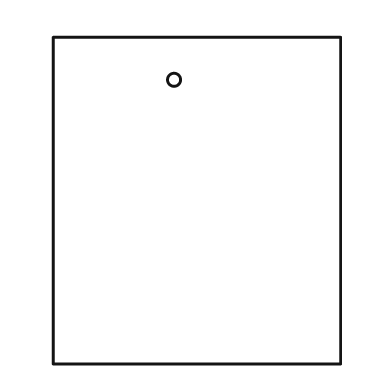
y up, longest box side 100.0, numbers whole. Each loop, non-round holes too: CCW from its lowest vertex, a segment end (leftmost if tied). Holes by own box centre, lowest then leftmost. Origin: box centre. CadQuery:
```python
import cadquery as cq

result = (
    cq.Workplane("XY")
    .moveTo(-44.0, -50.0)
    .lineTo(44.0, -50.0)
    .lineTo(44.0, 50.0)
    .lineTo(-44.0, 50.0)
    .close()
    .moveTo(-7.0, 37.0)
    .circle(2.0)
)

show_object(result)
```